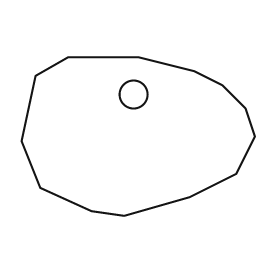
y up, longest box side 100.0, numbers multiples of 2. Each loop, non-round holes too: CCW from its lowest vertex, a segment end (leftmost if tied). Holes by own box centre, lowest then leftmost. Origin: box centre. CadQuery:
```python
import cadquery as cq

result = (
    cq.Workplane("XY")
    .moveTo(-6.0, -34.0)
    .lineTo(22.0, -26.0)
    .lineTo(42.0, -16.0)
    .lineTo(50.0, 0.0)
    .lineTo(46.0, 12.0)
    .lineTo(36.0, 22.0)
    .lineTo(24.0, 28.0)
    .lineTo(0.0, 34.0)
    .lineTo(-30.0, 34.0)
    .lineTo(-44.0, 26.0)
    .lineTo(-50.0, -2.0)
    .lineTo(-42.0, -22.0)
    .lineTo(-20.0, -32.0)
    .close()
    .moveTo(-2.0, 18.0)
    .circle(6.0)
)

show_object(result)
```